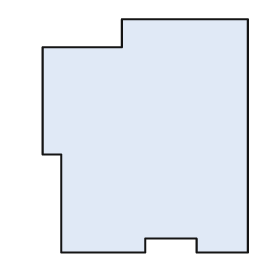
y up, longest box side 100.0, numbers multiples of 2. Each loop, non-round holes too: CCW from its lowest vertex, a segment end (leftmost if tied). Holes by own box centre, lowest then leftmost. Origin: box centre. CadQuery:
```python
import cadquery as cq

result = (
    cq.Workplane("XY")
    .moveTo(-36.0, -50.0)
    .lineTo(0.0, -50.0)
    .lineTo(0.0, -44.0)
    .lineTo(22.0, -44.0)
    .lineTo(22.0, -50.0)
    .lineTo(44.0, -50.0)
    .lineTo(44.0, 50.0)
    .lineTo(-10.0, 50.0)
    .lineTo(-10.0, 38.0)
    .lineTo(-44.0, 38.0)
    .lineTo(-44.0, -8.0)
    .lineTo(-36.0, -8.0)
    .close()
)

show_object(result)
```